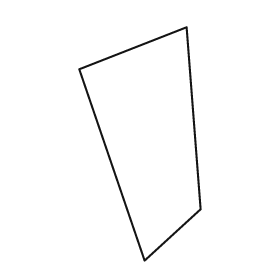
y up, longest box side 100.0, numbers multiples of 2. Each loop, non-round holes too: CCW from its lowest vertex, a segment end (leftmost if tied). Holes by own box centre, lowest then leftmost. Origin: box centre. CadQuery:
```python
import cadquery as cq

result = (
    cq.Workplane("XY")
    .moveTo(2.0, -50.0)
    .lineTo(26.0, -28.0)
    .lineTo(20.0, 50.0)
    .lineTo(-26.0, 32.0)
    .close()
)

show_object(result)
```